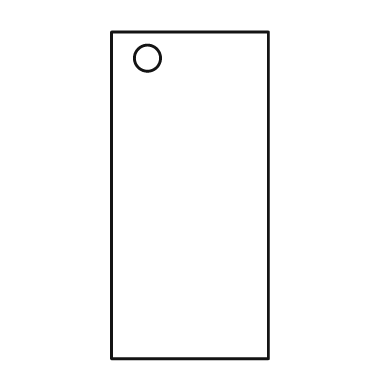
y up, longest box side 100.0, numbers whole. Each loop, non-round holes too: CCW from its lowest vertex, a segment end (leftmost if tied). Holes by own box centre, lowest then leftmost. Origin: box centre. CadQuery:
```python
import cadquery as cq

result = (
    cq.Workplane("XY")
    .moveTo(-24.0, -50.0)
    .lineTo(24.0, -50.0)
    .lineTo(24.0, 50.0)
    .lineTo(-24.0, 50.0)
    .close()
    .moveTo(-13.0, 42.0)
    .circle(4.0)
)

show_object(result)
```